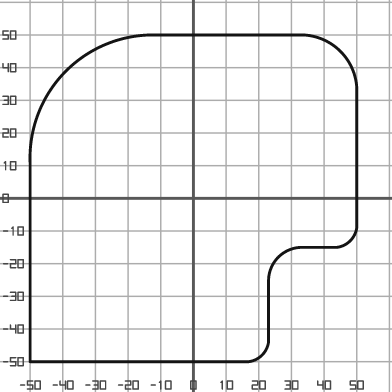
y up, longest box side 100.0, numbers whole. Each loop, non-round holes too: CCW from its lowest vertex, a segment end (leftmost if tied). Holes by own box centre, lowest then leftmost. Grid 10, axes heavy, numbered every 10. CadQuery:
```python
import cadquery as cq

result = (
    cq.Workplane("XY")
    .moveTo(-50.0, -50.0)
    .lineTo(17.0, -50.0)
    .threePointArc((21.0, -48.0), (23.0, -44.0))
    .lineTo(23.0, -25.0)
    .threePointArc((26.0, -18.0), (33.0, -15.0))
    .lineTo(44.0, -15.0)
    .threePointArc((48.0, -13.0), (50.0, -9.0))
    .lineTo(50.0, 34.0)
    .threePointArc((45.0, 45.0), (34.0, 50.0))
    .lineTo(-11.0, 50.0)
    .threePointArc((-39.0, 39.0), (-50.0, 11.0))
    .close()
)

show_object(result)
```